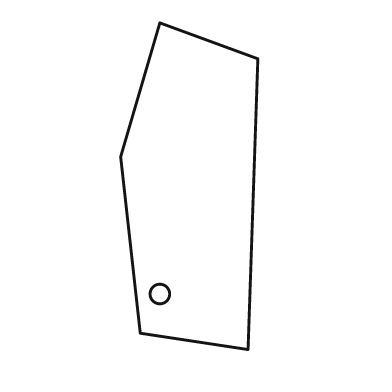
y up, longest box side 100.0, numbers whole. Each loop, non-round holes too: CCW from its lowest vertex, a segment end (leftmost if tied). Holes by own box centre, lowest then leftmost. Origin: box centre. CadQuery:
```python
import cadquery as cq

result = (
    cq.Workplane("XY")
    .moveTo(18.0, -50.0)
    .lineTo(21.0, 39.0)
    .lineTo(-9.0, 50.0)
    .lineTo(-21.0, 9.0)
    .lineTo(-15.0, -45.0)
    .close()
    .moveTo(-9.0, -33.0)
    .circle(3.0)
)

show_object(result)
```